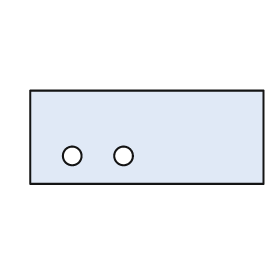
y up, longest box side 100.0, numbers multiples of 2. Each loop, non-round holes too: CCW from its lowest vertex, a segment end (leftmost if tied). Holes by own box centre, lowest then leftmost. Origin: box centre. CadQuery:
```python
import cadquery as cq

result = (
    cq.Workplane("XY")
    .moveTo(-50.0, -20.0)
    .lineTo(50.0, -20.0)
    .lineTo(50.0, 20.0)
    .lineTo(-50.0, 20.0)
    .close()
    .moveTo(-32.0, -8.0)
    .circle(4.0)
    .moveTo(-10.0, -8.0)
    .circle(4.0)
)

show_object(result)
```